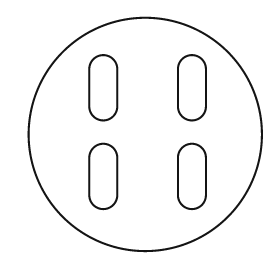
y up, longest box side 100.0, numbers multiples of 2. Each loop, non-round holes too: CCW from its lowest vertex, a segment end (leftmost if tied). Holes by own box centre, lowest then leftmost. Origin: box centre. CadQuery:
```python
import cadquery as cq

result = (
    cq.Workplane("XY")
    .moveTo(0.0, 0.0)
    .circle(50.0)
    .moveTo(-24.0, -26.0)
    .threePointArc((-18.0, -32.0), (-12.0, -26.0))
    .lineTo(-12.0, -10.0)
    .threePointArc((-18.0, -4.0), (-24.0, -10.0))
    .close()
    .moveTo(14.0, -26.0)
    .threePointArc((20.0, -32.0), (26.0, -26.0))
    .lineTo(26.0, -10.0)
    .threePointArc((20.0, -4.0), (14.0, -10.0))
    .close()
    .moveTo(-24.0, 12.0)
    .threePointArc((-18.0, 6.0), (-12.0, 12.0))
    .lineTo(-12.0, 28.0)
    .threePointArc((-18.0, 34.0), (-24.0, 28.0))
    .close()
    .moveTo(14.0, 12.0)
    .threePointArc((20.0, 6.0), (26.0, 12.0))
    .lineTo(26.0, 28.0)
    .threePointArc((20.0, 34.0), (14.0, 28.0))
    .close()
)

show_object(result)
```